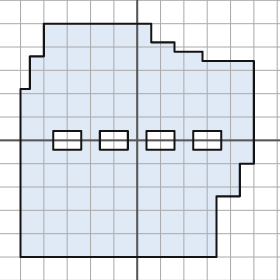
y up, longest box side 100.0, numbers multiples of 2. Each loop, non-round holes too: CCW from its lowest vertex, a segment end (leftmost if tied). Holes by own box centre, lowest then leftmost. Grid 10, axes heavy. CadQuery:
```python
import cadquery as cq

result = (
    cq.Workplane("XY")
    .moveTo(-50.0, -50.0)
    .lineTo(34.0, -50.0)
    .lineTo(34.0, -24.0)
    .lineTo(44.0, -24.0)
    .lineTo(44.0, -10.0)
    .lineTo(50.0, -10.0)
    .lineTo(50.0, 34.0)
    .lineTo(28.0, 34.0)
    .lineTo(28.0, 38.0)
    .lineTo(16.0, 38.0)
    .lineTo(16.0, 42.0)
    .lineTo(6.0, 42.0)
    .lineTo(6.0, 50.0)
    .lineTo(-40.0, 50.0)
    .lineTo(-40.0, 36.0)
    .lineTo(-46.0, 36.0)
    .lineTo(-46.0, 22.0)
    .lineTo(-50.0, 22.0)
    .close()
    .moveTo(-36.0, -4.0)
    .lineTo(-24.0, -4.0)
    .lineTo(-24.0, 4.0)
    .lineTo(-36.0, 4.0)
    .close()
    .moveTo(-16.0, -4.0)
    .lineTo(-4.0, -4.0)
    .lineTo(-4.0, 4.0)
    .lineTo(-16.0, 4.0)
    .close()
    .moveTo(4.0, -4.0)
    .lineTo(16.0, -4.0)
    .lineTo(16.0, 4.0)
    .lineTo(4.0, 4.0)
    .close()
    .moveTo(24.0, -4.0)
    .lineTo(36.0, -4.0)
    .lineTo(36.0, 4.0)
    .lineTo(24.0, 4.0)
    .close()
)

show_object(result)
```